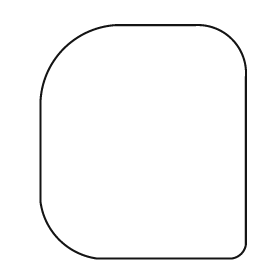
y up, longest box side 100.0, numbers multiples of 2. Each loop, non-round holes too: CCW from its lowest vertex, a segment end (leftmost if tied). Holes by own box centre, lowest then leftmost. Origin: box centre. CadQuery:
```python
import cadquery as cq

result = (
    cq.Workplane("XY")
    .moveTo(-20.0, -50.0)
    .lineTo(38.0, -50.0)
    .threePointArc((42.0, -48.0), (44.0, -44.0))
    .lineTo(44.0, 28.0)
    .threePointArc((38.0, 44.0), (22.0, 50.0))
    .lineTo(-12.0, 50.0)
    .threePointArc((-34.0, 40.0), (-44.0, 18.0))
    .lineTo(-44.0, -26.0)
    .threePointArc((-36.0, -42.0), (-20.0, -50.0))
    .close()
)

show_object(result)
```